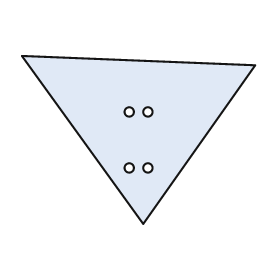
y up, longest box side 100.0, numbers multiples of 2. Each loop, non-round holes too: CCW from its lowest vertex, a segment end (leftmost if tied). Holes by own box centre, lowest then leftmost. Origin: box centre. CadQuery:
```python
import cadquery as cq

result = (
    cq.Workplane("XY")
    .moveTo(2.0, -36.0)
    .lineTo(50.0, 32.0)
    .lineTo(-50.0, 36.0)
    .close()
    .moveTo(-4.0, -12.0)
    .circle(2.0)
    .moveTo(4.0, -12.0)
    .circle(2.0)
    .moveTo(-4.0, 12.0)
    .circle(2.0)
    .moveTo(4.0, 12.0)
    .circle(2.0)
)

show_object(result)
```